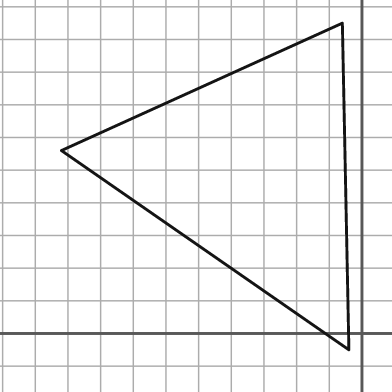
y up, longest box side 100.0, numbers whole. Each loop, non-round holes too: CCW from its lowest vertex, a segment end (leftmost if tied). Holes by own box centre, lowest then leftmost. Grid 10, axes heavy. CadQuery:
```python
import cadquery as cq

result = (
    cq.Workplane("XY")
    .moveTo(-4.0, -5.0)
    .lineTo(-6.0, 95.0)
    .lineTo(-92.0, 56.0)
    .close()
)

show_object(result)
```